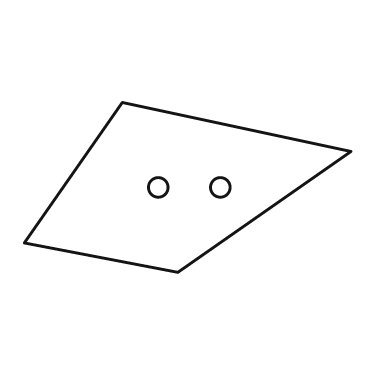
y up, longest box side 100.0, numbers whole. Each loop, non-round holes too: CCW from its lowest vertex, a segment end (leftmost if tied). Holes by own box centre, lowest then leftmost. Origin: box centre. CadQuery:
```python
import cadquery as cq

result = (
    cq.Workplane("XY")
    .moveTo(-3.0, -26.0)
    .lineTo(50.0, 11.0)
    .lineTo(-20.0, 26.0)
    .lineTo(-50.0, -17.0)
    .close()
    .moveTo(-9.0, 0.0)
    .circle(3.0)
    .moveTo(10.0, 0.0)
    .circle(3.0)
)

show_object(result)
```